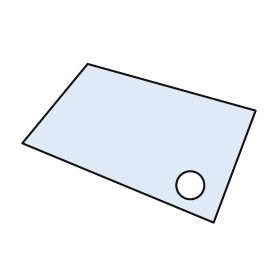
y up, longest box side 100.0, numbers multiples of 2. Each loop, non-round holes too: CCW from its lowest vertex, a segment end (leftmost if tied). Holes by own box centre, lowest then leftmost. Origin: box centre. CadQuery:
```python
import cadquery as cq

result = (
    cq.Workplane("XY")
    .moveTo(32.0, -34.0)
    .lineTo(50.0, 14.0)
    .lineTo(-22.0, 34.0)
    .lineTo(-50.0, 0.0)
    .close()
    .moveTo(22.0, -18.0)
    .circle(6.0)
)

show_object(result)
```